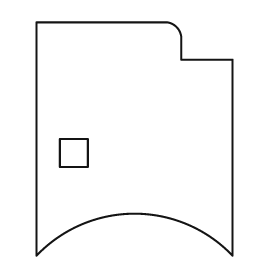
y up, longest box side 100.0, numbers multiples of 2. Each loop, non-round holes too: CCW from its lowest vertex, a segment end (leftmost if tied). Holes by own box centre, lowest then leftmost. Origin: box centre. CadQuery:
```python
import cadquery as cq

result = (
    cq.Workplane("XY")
    .moveTo(-42.0, -50.0)
    .threePointArc((0.0, -32.0), (42.0, -50.0))
    .lineTo(42.0, 34.0)
    .lineTo(20.0, 34.0)
    .lineTo(20.0, 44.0)
    .threePointArc((18.0, 48.0), (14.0, 50.0))
    .lineTo(-42.0, 50.0)
    .close()
    .moveTo(-32.0, -12.0)
    .lineTo(-20.0, -12.0)
    .lineTo(-20.0, 0.0)
    .lineTo(-32.0, 0.0)
    .close()
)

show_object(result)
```